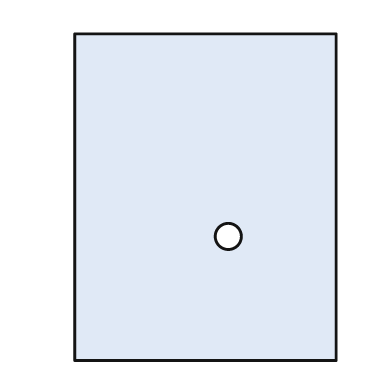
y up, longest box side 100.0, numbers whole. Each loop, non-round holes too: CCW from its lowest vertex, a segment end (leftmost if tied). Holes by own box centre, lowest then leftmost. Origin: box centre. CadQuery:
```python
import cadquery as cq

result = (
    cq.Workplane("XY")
    .moveTo(-40.0, -50.0)
    .lineTo(40.0, -50.0)
    .lineTo(40.0, 50.0)
    .lineTo(-40.0, 50.0)
    .close()
    .moveTo(7.0, -12.0)
    .circle(4.0)
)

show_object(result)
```